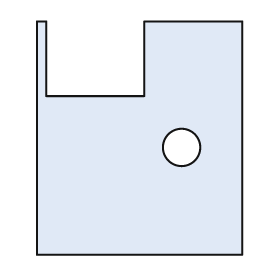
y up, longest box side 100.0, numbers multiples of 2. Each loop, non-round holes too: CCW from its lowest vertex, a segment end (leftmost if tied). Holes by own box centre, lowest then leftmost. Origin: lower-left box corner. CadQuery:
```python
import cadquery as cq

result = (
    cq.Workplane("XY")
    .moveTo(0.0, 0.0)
    .lineTo(88.0, 0.0)
    .lineTo(88.0, 100.0)
    .lineTo(46.0, 100.0)
    .lineTo(46.0, 68.0)
    .lineTo(4.0, 68.0)
    .lineTo(4.0, 100.0)
    .lineTo(0.0, 100.0)
    .close()
    .moveTo(62.0, 46.0)
    .circle(8.0)
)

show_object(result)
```